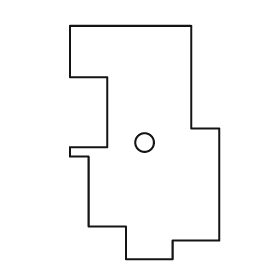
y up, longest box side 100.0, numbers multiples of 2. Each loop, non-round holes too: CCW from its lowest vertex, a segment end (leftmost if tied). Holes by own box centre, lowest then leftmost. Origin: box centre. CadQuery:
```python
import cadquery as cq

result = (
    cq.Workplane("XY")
    .moveTo(-8.0, -50.0)
    .lineTo(12.0, -50.0)
    .lineTo(12.0, -42.0)
    .lineTo(32.0, -42.0)
    .lineTo(32.0, 6.0)
    .lineTo(20.0, 6.0)
    .lineTo(20.0, 50.0)
    .lineTo(-32.0, 50.0)
    .lineTo(-32.0, 28.0)
    .lineTo(-16.0, 28.0)
    .lineTo(-16.0, -2.0)
    .lineTo(-32.0, -2.0)
    .lineTo(-32.0, -6.0)
    .lineTo(-24.0, -6.0)
    .lineTo(-24.0, -36.0)
    .lineTo(-8.0, -36.0)
    .close()
    .moveTo(0.0, 0.0)
    .circle(4.0)
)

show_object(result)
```